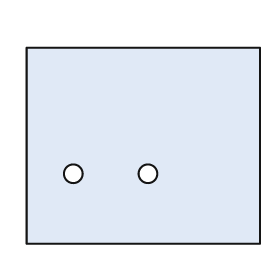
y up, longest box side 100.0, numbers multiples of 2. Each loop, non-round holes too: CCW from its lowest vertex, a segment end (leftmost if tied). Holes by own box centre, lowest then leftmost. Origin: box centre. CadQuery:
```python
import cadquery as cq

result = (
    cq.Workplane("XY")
    .moveTo(-50.0, -42.0)
    .lineTo(50.0, -42.0)
    .lineTo(50.0, 42.0)
    .lineTo(-50.0, 42.0)
    .close()
    .moveTo(-30.0, -12.0)
    .circle(4.0)
    .moveTo(2.0, -12.0)
    .circle(4.0)
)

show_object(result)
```